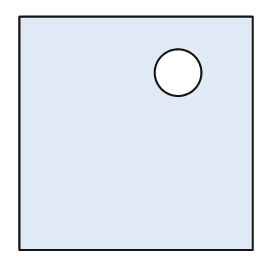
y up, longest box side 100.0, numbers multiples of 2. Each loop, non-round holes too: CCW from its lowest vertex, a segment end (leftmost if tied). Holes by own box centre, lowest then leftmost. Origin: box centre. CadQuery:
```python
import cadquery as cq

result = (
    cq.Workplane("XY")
    .moveTo(-50.0, -50.0)
    .lineTo(50.0, -50.0)
    .lineTo(50.0, 50.0)
    .lineTo(-50.0, 50.0)
    .close()
    .moveTo(18.0, 26.0)
    .circle(10.0)
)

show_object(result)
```